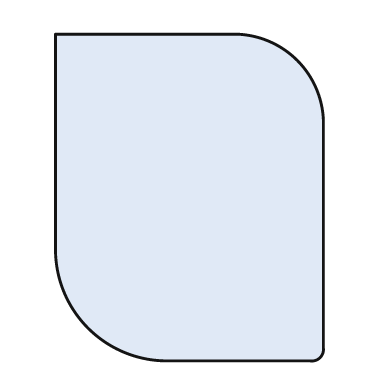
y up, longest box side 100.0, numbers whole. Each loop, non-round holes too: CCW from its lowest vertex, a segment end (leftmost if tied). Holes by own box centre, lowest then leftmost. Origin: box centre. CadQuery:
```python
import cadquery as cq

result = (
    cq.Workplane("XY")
    .moveTo(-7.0, -50.0)
    .lineTo(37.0, -50.0)
    .threePointArc((40.0, -49.0), (41.0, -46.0))
    .lineTo(41.0, 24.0)
    .threePointArc((33.0, 42.0), (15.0, 50.0))
    .lineTo(-41.0, 50.0)
    .lineTo(-41.0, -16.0)
    .threePointArc((-31.0, -40.0), (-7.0, -50.0))
    .close()
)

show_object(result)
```